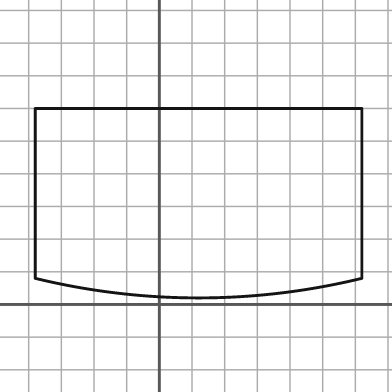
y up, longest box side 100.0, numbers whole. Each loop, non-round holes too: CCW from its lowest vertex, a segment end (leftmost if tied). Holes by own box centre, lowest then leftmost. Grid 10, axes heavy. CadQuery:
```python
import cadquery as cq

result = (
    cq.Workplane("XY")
    .moveTo(-38.0, 8.0)
    .threePointArc((12.0, 2.0), (62.0, 8.0))
    .lineTo(62.0, 60.0)
    .lineTo(-38.0, 60.0)
    .close()
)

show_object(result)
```